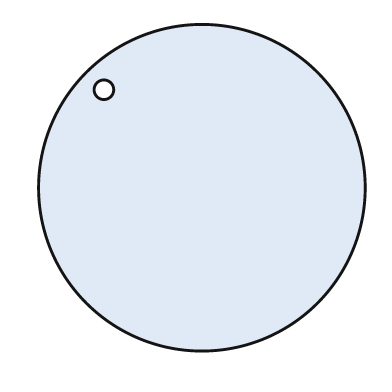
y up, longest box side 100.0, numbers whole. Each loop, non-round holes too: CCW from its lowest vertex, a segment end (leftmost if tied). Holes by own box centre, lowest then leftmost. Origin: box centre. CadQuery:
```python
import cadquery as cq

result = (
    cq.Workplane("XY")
    .moveTo(0.0, 0.0)
    .circle(50.0)
    .moveTo(-30.0, 30.0)
    .circle(3.0)
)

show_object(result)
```